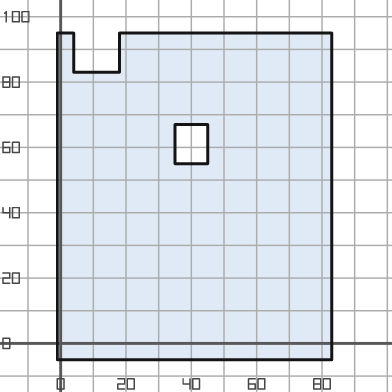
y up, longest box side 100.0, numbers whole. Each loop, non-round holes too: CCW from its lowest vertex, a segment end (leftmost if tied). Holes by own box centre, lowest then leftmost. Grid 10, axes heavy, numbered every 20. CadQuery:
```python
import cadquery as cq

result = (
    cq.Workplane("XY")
    .moveTo(-1.0, -5.0)
    .lineTo(83.0, -5.0)
    .lineTo(83.0, 95.0)
    .lineTo(18.0, 95.0)
    .lineTo(18.0, 83.0)
    .lineTo(4.0, 83.0)
    .lineTo(4.0, 95.0)
    .lineTo(-1.0, 95.0)
    .close()
    .moveTo(35.0, 55.0)
    .lineTo(45.0, 55.0)
    .lineTo(45.0, 67.0)
    .lineTo(35.0, 67.0)
    .close()
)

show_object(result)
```